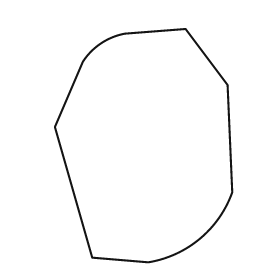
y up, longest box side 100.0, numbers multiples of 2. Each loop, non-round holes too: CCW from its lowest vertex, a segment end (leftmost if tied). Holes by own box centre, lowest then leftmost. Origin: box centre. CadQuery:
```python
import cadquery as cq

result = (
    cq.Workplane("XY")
    .moveTo(2.0, -50.0)
    .threePointArc((24.0, -40.0), (38.0, -20.0))
    .lineTo(36.0, 26.0)
    .lineTo(18.0, 50.0)
    .lineTo(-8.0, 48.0)
    .threePointArc((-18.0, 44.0), (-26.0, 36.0))
    .lineTo(-38.0, 8.0)
    .lineTo(-22.0, -48.0)
    .close()
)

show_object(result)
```